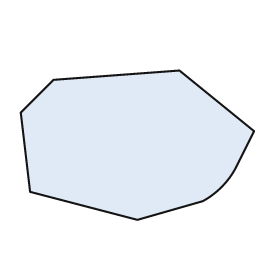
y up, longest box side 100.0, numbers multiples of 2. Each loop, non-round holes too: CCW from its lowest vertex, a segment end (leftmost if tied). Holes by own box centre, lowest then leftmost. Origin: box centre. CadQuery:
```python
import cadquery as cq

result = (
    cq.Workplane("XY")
    .moveTo(0.0, -32.0)
    .lineTo(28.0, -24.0)
    .threePointArc((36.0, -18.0), (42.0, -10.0))
    .lineTo(50.0, 6.0)
    .lineTo(18.0, 32.0)
    .lineTo(-36.0, 28.0)
    .lineTo(-50.0, 14.0)
    .lineTo(-46.0, -20.0)
    .close()
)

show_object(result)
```